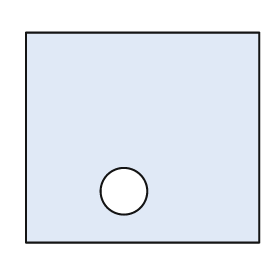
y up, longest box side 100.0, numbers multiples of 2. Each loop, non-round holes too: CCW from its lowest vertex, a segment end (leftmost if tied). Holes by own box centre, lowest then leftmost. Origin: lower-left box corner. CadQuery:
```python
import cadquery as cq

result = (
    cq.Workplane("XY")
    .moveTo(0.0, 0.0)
    .lineTo(100.0, 0.0)
    .lineTo(100.0, 90.0)
    .lineTo(0.0, 90.0)
    .close()
    .moveTo(42.0, 22.0)
    .circle(10.0)
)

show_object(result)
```